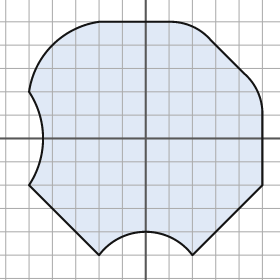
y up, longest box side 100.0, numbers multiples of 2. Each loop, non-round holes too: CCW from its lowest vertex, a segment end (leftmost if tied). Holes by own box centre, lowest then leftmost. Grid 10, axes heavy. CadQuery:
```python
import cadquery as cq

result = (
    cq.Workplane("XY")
    .moveTo(-20.0, -50.0)
    .threePointArc((0.0, -40.0), (20.0, -50.0))
    .lineTo(50.0, -20.0)
    .lineTo(50.0, 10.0)
    .threePointArc((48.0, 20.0), (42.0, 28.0))
    .lineTo(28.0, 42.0)
    .threePointArc((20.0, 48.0), (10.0, 50.0))
    .lineTo(-20.0, 50.0)
    .threePointArc((-40.0, 40.0), (-50.0, 20.0))
    .threePointArc((-44.0, 0.0), (-50.0, -20.0))
    .close()
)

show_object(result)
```